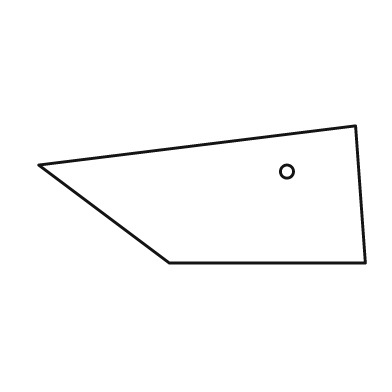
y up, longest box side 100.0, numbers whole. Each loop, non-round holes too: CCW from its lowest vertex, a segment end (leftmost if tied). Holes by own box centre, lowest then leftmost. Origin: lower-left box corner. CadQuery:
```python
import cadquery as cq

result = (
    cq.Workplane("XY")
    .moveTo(40.0, 0.0)
    .lineTo(100.0, 0.0)
    .lineTo(97.0, 42.0)
    .lineTo(0.0, 30.0)
    .close()
    .moveTo(76.0, 28.0)
    .circle(2.0)
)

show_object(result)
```